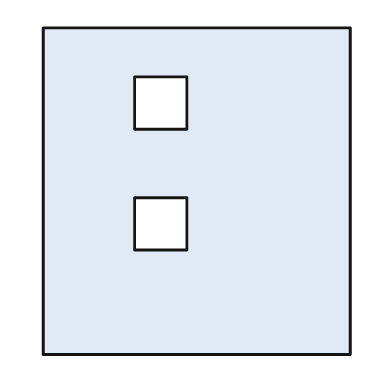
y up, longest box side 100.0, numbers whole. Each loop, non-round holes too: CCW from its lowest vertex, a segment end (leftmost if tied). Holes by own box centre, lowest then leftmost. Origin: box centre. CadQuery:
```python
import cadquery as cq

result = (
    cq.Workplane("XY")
    .moveTo(-47.0, -50.0)
    .lineTo(47.0, -50.0)
    .lineTo(47.0, 50.0)
    .lineTo(-47.0, 50.0)
    .close()
    .moveTo(-19.0, -18.0)
    .lineTo(-3.0, -18.0)
    .lineTo(-3.0, -2.0)
    .lineTo(-19.0, -2.0)
    .close()
    .moveTo(-19.0, 19.0)
    .lineTo(-3.0, 19.0)
    .lineTo(-3.0, 35.0)
    .lineTo(-19.0, 35.0)
    .close()
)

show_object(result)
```